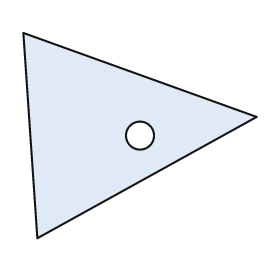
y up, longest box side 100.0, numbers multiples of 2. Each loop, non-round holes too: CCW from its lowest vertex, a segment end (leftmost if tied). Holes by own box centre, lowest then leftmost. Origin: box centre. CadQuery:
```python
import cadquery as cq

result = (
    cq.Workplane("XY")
    .moveTo(-44.0, -44.0)
    .lineTo(50.0, 8.0)
    .lineTo(-50.0, 44.0)
    .close()
    .moveTo(0.0, 0.0)
    .circle(6.0)
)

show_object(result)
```